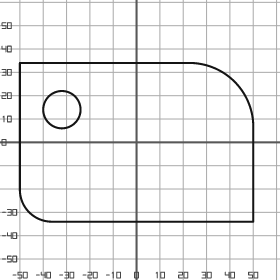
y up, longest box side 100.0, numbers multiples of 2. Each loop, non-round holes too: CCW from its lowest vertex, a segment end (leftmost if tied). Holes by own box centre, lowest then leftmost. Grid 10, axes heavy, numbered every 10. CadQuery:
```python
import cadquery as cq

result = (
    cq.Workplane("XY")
    .moveTo(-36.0, -34.0)
    .lineTo(50.0, -34.0)
    .lineTo(50.0, 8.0)
    .threePointArc((42.0, 26.0), (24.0, 34.0))
    .lineTo(-50.0, 34.0)
    .lineTo(-50.0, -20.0)
    .threePointArc((-46.0, -30.0), (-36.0, -34.0))
    .close()
    .moveTo(-32.0, 14.0)
    .circle(8.0)
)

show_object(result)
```